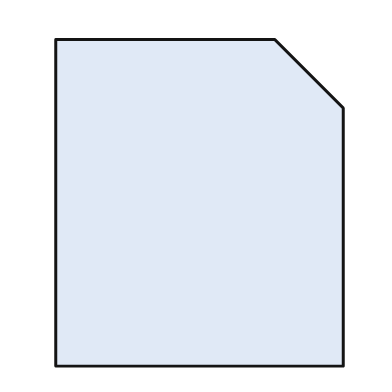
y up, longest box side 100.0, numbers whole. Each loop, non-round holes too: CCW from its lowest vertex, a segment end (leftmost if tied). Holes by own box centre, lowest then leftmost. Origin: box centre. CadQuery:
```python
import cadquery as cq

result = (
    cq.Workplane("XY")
    .moveTo(-44.0, -50.0)
    .lineTo(44.0, -50.0)
    .lineTo(44.0, 29.0)
    .lineTo(23.0, 50.0)
    .lineTo(-44.0, 50.0)
    .close()
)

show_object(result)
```